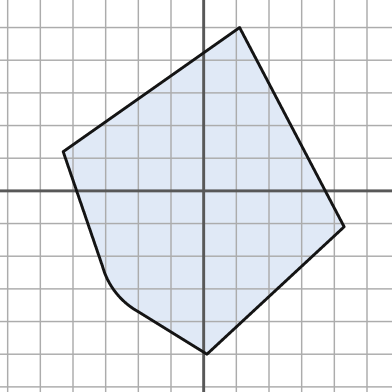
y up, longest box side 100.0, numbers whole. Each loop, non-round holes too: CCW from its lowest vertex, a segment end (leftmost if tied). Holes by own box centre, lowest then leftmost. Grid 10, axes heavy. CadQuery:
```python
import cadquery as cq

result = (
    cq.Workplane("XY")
    .moveTo(1.0, -50.0)
    .lineTo(43.0, -11.0)
    .lineTo(11.0, 50.0)
    .lineTo(-43.0, 12.0)
    .lineTo(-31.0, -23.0)
    .threePointArc((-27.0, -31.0), (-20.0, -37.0))
    .close()
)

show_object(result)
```